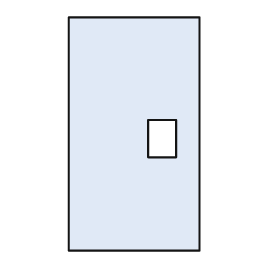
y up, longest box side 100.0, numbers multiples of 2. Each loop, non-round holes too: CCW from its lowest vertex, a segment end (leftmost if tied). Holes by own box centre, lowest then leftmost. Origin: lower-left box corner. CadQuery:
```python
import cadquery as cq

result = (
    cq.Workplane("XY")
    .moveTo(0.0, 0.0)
    .lineTo(56.0, 0.0)
    .lineTo(56.0, 100.0)
    .lineTo(0.0, 100.0)
    .close()
    .moveTo(34.0, 40.0)
    .lineTo(46.0, 40.0)
    .lineTo(46.0, 56.0)
    .lineTo(34.0, 56.0)
    .close()
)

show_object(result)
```